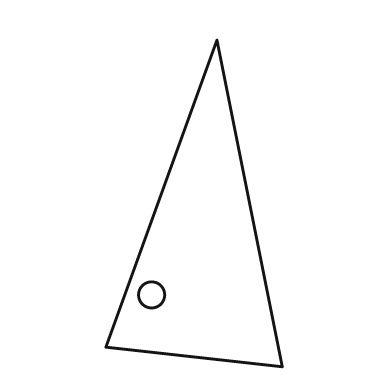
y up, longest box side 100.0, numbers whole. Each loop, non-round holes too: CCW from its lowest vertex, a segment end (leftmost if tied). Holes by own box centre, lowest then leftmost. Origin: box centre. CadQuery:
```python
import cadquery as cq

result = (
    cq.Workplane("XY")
    .moveTo(27.0, -50.0)
    .lineTo(7.0, 50.0)
    .lineTo(-27.0, -44.0)
    .close()
    .moveTo(-13.0, -28.0)
    .circle(4.0)
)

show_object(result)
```